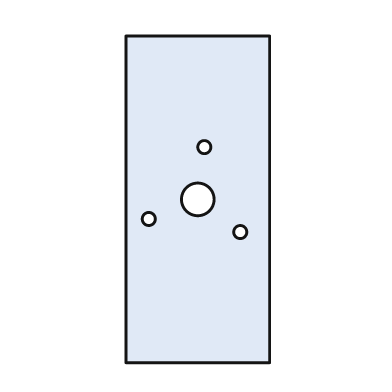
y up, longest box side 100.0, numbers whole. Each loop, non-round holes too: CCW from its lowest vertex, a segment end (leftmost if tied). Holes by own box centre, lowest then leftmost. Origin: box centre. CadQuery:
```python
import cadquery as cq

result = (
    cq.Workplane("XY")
    .moveTo(-22.0, -50.0)
    .lineTo(22.0, -50.0)
    .lineTo(22.0, 50.0)
    .lineTo(-22.0, 50.0)
    .close()
    .moveTo(13.0, -10.0)
    .circle(2.0)
    .moveTo(-15.0, -6.0)
    .circle(2.0)
    .moveTo(0.0, 0.0)
    .circle(5.0)
    .moveTo(2.0, 16.0)
    .circle(2.0)
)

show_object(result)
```